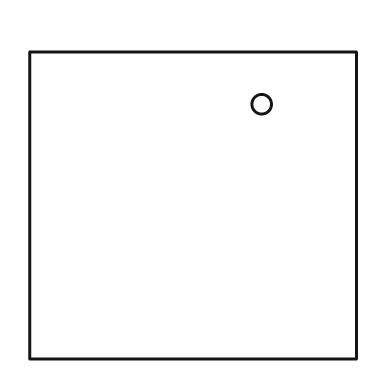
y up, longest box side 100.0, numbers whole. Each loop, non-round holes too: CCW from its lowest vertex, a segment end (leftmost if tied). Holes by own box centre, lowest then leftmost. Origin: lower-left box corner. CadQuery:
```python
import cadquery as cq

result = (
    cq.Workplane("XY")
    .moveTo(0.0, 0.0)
    .lineTo(100.0, 0.0)
    .lineTo(100.0, 94.0)
    .lineTo(0.0, 94.0)
    .close()
    .moveTo(71.0, 78.0)
    .circle(3.0)
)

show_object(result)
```